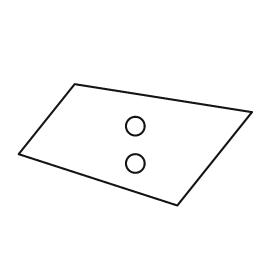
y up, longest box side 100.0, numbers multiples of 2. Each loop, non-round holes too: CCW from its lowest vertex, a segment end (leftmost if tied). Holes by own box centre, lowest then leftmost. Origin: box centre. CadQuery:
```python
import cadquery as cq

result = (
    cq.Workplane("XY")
    .moveTo(18.0, -26.0)
    .lineTo(50.0, 14.0)
    .lineTo(-26.0, 26.0)
    .lineTo(-50.0, -4.0)
    .close()
    .moveTo(0.0, -8.0)
    .circle(4.0)
    .moveTo(0.0, 8.0)
    .circle(4.0)
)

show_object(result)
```